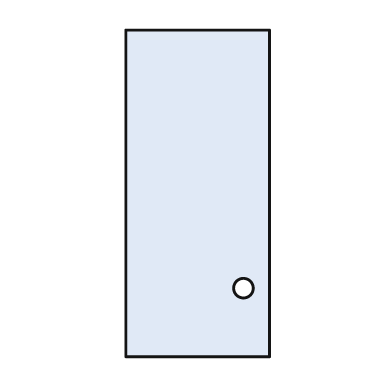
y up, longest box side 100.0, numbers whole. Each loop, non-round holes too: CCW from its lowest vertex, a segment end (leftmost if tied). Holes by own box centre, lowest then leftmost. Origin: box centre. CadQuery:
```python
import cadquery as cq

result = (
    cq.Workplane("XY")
    .moveTo(-22.0, -50.0)
    .lineTo(22.0, -50.0)
    .lineTo(22.0, 50.0)
    .lineTo(-22.0, 50.0)
    .close()
    .moveTo(14.0, -29.0)
    .circle(3.0)
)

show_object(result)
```